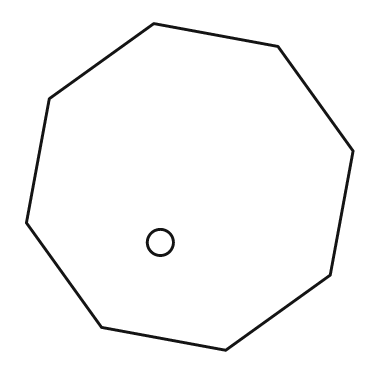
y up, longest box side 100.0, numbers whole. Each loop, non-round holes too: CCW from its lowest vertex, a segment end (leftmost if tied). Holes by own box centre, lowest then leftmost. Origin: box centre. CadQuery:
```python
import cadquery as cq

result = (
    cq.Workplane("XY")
    .moveTo(11.0, -50.0)
    .lineTo(43.0, -27.0)
    .lineTo(50.0, 11.0)
    .lineTo(27.0, 43.0)
    .lineTo(-11.0, 50.0)
    .lineTo(-43.0, 27.0)
    .lineTo(-50.0, -11.0)
    .lineTo(-27.0, -43.0)
    .close()
    .moveTo(-9.0, -17.0)
    .circle(4.0)
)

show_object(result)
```